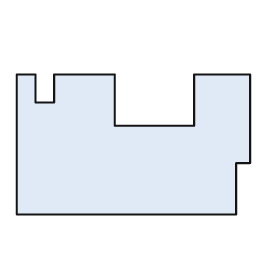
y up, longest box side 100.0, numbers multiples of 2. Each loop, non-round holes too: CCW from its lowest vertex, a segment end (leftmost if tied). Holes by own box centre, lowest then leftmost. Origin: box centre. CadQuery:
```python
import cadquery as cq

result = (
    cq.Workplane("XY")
    .moveTo(-50.0, -30.0)
    .lineTo(44.0, -30.0)
    .lineTo(44.0, -8.0)
    .lineTo(50.0, -8.0)
    .lineTo(50.0, 30.0)
    .lineTo(26.0, 30.0)
    .lineTo(26.0, 8.0)
    .lineTo(-8.0, 8.0)
    .lineTo(-8.0, 30.0)
    .lineTo(-34.0, 30.0)
    .lineTo(-34.0, 18.0)
    .lineTo(-42.0, 18.0)
    .lineTo(-42.0, 30.0)
    .lineTo(-50.0, 30.0)
    .close()
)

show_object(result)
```